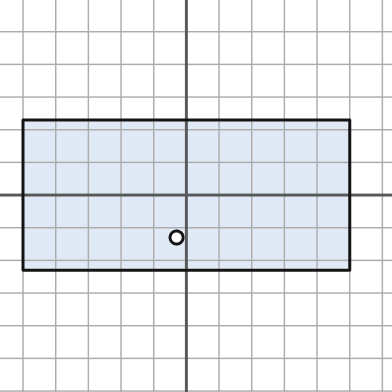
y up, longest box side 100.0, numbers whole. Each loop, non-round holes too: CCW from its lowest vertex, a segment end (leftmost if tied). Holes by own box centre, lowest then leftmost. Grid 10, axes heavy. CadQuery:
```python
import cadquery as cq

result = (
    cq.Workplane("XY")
    .moveTo(-50.0, -23.0)
    .lineTo(50.0, -23.0)
    .lineTo(50.0, 23.0)
    .lineTo(-50.0, 23.0)
    .close()
    .moveTo(-3.0, -13.0)
    .circle(2.0)
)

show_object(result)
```